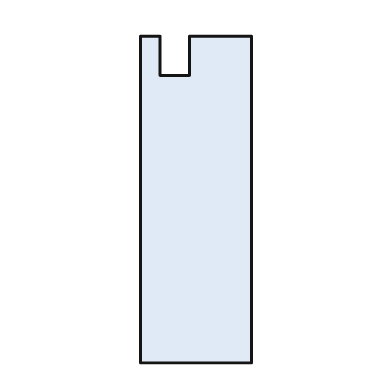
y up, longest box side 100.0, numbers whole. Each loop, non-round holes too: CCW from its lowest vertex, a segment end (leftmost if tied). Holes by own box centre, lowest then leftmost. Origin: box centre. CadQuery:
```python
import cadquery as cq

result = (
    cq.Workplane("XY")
    .moveTo(-17.0, -50.0)
    .lineTo(17.0, -50.0)
    .lineTo(17.0, 50.0)
    .lineTo(-2.0, 50.0)
    .lineTo(-2.0, 38.0)
    .lineTo(-11.0, 38.0)
    .lineTo(-11.0, 50.0)
    .lineTo(-17.0, 50.0)
    .close()
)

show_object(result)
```